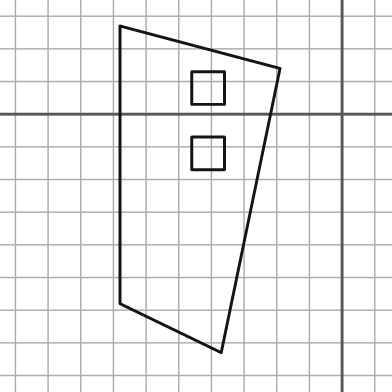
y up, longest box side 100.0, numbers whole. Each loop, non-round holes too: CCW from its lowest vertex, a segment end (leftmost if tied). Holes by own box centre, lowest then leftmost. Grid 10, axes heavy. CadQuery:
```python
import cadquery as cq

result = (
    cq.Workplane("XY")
    .moveTo(-37.0, -73.0)
    .lineTo(-19.0, 14.0)
    .lineTo(-68.0, 27.0)
    .lineTo(-68.0, -58.0)
    .close()
    .moveTo(-46.0, -17.0)
    .lineTo(-36.0, -17.0)
    .lineTo(-36.0, -7.0)
    .lineTo(-46.0, -7.0)
    .close()
    .moveTo(-46.0, 3.0)
    .lineTo(-36.0, 3.0)
    .lineTo(-36.0, 13.0)
    .lineTo(-46.0, 13.0)
    .close()
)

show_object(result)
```